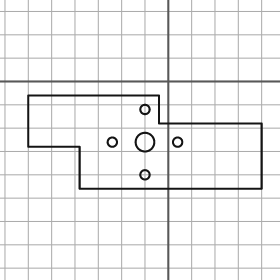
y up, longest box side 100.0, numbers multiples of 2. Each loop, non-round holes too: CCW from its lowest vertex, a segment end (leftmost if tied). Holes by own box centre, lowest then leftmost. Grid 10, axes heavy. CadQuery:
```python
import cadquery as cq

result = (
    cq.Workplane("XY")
    .moveTo(-38.0, -46.0)
    .lineTo(40.0, -46.0)
    .lineTo(40.0, -18.0)
    .lineTo(-4.0, -18.0)
    .lineTo(-4.0, -6.0)
    .lineTo(-60.0, -6.0)
    .lineTo(-60.0, -28.0)
    .lineTo(-38.0, -28.0)
    .close()
    .moveTo(-10.0, -40.0)
    .circle(2.0)
    .moveTo(-24.0, -26.0)
    .circle(2.0)
    .moveTo(-10.0, -26.0)
    .circle(4.0)
    .moveTo(4.0, -26.0)
    .circle(2.0)
    .moveTo(-10.0, -12.0)
    .circle(2.0)
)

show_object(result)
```